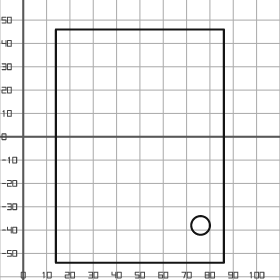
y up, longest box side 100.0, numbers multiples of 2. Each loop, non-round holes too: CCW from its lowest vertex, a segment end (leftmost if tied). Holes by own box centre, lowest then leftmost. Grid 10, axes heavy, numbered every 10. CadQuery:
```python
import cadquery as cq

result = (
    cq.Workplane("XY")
    .moveTo(14.0, -54.0)
    .lineTo(86.0, -54.0)
    .lineTo(86.0, 46.0)
    .lineTo(14.0, 46.0)
    .close()
    .moveTo(76.0, -38.0)
    .circle(4.0)
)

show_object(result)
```